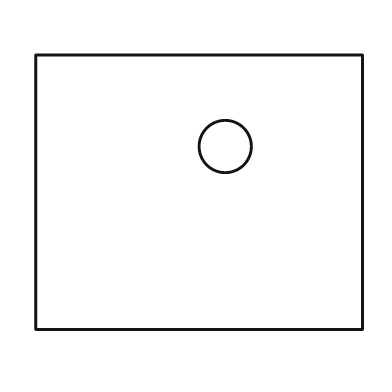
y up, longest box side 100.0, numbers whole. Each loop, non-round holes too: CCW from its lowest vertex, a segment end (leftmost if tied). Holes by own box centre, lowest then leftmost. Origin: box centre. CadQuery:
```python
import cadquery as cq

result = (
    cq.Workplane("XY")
    .moveTo(-50.0, -42.0)
    .lineTo(50.0, -42.0)
    .lineTo(50.0, 42.0)
    .lineTo(-50.0, 42.0)
    .close()
    .moveTo(8.0, 14.0)
    .circle(8.0)
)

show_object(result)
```